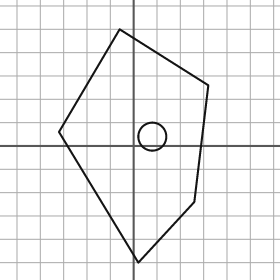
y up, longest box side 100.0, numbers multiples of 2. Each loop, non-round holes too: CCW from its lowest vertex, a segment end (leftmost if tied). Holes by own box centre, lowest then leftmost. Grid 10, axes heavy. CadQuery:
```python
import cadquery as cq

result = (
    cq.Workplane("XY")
    .moveTo(2.0, -50.0)
    .lineTo(26.0, -24.0)
    .lineTo(32.0, 26.0)
    .lineTo(-6.0, 50.0)
    .lineTo(-32.0, 6.0)
    .close()
    .moveTo(8.0, 4.0)
    .circle(6.0)
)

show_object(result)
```